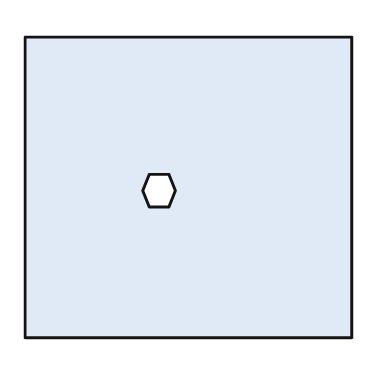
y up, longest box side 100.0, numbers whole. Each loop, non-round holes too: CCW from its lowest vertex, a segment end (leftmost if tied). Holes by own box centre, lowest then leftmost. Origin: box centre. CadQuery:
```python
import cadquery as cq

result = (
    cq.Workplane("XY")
    .moveTo(-50.0, -46.0)
    .lineTo(50.0, -46.0)
    .lineTo(50.0, 46.0)
    .lineTo(-50.0, 46.0)
    .close()
    .moveTo(-12.0, -6.0)
    .lineTo(-6.0, -6.0)
    .lineTo(-4.0, -1.0)
    .lineTo(-6.0, 4.0)
    .lineTo(-12.0, 4.0)
    .lineTo(-14.0, -1.0)
    .close()
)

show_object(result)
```